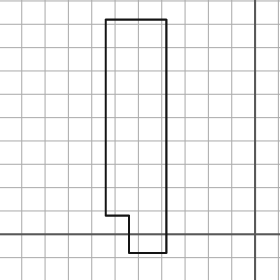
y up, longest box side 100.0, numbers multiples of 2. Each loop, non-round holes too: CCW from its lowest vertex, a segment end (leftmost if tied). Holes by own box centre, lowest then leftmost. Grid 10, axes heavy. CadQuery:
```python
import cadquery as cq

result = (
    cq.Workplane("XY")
    .moveTo(-54.0, -8.0)
    .lineTo(-38.0, -8.0)
    .lineTo(-38.0, 92.0)
    .lineTo(-64.0, 92.0)
    .lineTo(-64.0, 8.0)
    .lineTo(-54.0, 8.0)
    .close()
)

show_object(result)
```